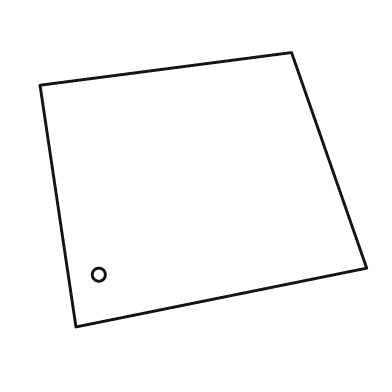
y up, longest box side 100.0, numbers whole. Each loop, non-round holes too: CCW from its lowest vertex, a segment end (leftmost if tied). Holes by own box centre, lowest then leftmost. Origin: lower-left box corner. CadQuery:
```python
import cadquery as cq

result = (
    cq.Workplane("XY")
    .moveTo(11.0, 0.0)
    .lineTo(100.0, 18.0)
    .lineTo(77.0, 84.0)
    .lineTo(0.0, 74.0)
    .close()
    .moveTo(18.0, 16.0)
    .circle(2.0)
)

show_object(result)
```